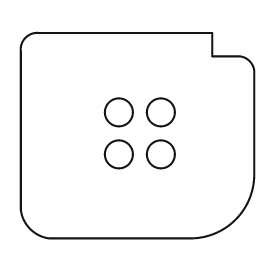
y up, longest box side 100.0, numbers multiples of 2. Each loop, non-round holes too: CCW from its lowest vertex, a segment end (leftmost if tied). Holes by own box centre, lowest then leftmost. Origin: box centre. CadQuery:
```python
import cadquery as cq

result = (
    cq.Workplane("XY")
    .moveTo(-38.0, -44.0)
    .lineTo(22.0, -44.0)
    .threePointArc((42.0, -36.0), (50.0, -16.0))
    .lineTo(50.0, 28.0)
    .threePointArc((48.0, 32.0), (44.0, 34.0))
    .lineTo(32.0, 34.0)
    .lineTo(32.0, 44.0)
    .lineTo(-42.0, 44.0)
    .threePointArc((-48.0, 42.0), (-50.0, 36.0))
    .lineTo(-50.0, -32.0)
    .threePointArc((-46.0, -40.0), (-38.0, -44.0))
    .close()
    .moveTo(-8.0, -8.0)
    .circle(6.0)
    .moveTo(10.0, -8.0)
    .circle(6.0)
    .moveTo(-8.0, 10.0)
    .circle(6.0)
    .moveTo(10.0, 10.0)
    .circle(6.0)
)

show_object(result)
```